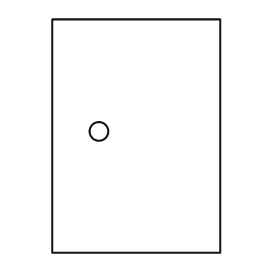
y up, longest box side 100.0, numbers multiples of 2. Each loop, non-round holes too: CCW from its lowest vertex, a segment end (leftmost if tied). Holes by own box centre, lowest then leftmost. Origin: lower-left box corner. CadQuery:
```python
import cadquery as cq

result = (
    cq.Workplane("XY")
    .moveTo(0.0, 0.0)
    .lineTo(72.0, 0.0)
    .lineTo(72.0, 100.0)
    .lineTo(0.0, 100.0)
    .close()
    .moveTo(20.0, 52.0)
    .circle(4.0)
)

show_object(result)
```